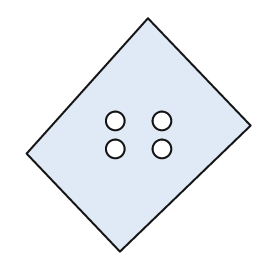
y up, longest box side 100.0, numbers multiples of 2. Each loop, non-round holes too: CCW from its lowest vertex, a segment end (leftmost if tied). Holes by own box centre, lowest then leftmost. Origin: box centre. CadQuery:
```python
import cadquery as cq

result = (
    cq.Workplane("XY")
    .moveTo(-8.0, -50.0)
    .lineTo(48.0, 4.0)
    .lineTo(4.0, 50.0)
    .lineTo(-48.0, -8.0)
    .close()
    .moveTo(-10.0, -6.0)
    .circle(4.0)
    .moveTo(10.0, -6.0)
    .circle(4.0)
    .moveTo(-10.0, 6.0)
    .circle(4.0)
    .moveTo(10.0, 6.0)
    .circle(4.0)
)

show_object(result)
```